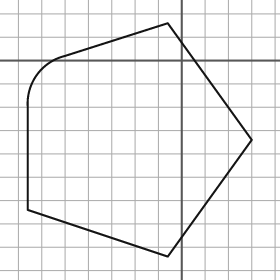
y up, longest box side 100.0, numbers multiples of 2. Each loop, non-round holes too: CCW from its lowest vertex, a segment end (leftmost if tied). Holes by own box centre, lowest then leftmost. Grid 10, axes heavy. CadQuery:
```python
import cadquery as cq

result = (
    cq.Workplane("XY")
    .moveTo(-6.0, -84.0)
    .lineTo(30.0, -34.0)
    .lineTo(-6.0, 16.0)
    .lineTo(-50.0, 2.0)
    .threePointArc((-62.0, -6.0), (-66.0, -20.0))
    .lineTo(-66.0, -64.0)
    .close()
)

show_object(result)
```